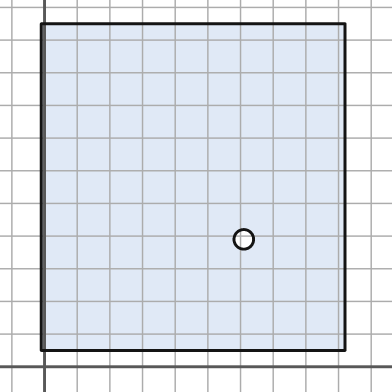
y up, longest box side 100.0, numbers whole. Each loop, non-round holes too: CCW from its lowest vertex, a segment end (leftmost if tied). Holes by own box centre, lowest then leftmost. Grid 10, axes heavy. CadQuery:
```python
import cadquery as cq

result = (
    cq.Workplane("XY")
    .moveTo(-1.0, 5.0)
    .lineTo(92.0, 5.0)
    .lineTo(92.0, 105.0)
    .lineTo(-1.0, 105.0)
    .close()
    .moveTo(61.0, 39.0)
    .circle(3.0)
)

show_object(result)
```